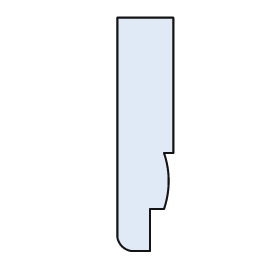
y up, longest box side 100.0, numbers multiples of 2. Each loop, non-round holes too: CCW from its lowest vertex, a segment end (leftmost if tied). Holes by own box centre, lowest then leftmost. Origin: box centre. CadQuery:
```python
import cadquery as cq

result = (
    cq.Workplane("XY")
    .moveTo(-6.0, -50.0)
    .lineTo(2.0, -50.0)
    .lineTo(2.0, -32.0)
    .lineTo(8.0, -32.0)
    .threePointArc((10.0, -20.0), (8.0, -8.0))
    .lineTo(12.0, -8.0)
    .lineTo(12.0, 50.0)
    .lineTo(-12.0, 50.0)
    .lineTo(-12.0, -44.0)
    .threePointArc((-10.0, -48.0), (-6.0, -50.0))
    .close()
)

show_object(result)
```